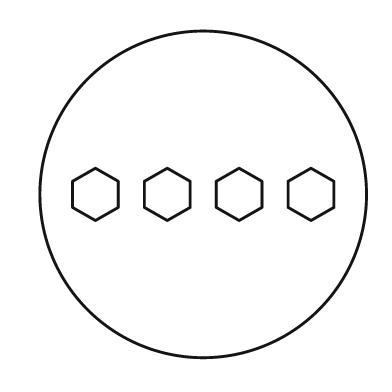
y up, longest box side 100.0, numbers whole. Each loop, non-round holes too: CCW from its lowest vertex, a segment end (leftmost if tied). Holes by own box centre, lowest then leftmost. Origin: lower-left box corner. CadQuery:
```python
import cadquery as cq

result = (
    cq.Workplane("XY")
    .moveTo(50.0, 50.0)
    .circle(50.0)
    .moveTo(17.0, 42.0)
    .lineTo(24.0, 46.0)
    .lineTo(24.0, 54.0)
    .lineTo(17.0, 58.0)
    .lineTo(10.0, 54.0)
    .lineTo(10.0, 46.0)
    .close()
    .moveTo(39.0, 42.0)
    .lineTo(46.0, 46.0)
    .lineTo(46.0, 54.0)
    .lineTo(39.0, 58.0)
    .lineTo(32.0, 54.0)
    .lineTo(32.0, 46.0)
    .close()
    .moveTo(61.0, 42.0)
    .lineTo(68.0, 46.0)
    .lineTo(68.0, 54.0)
    .lineTo(61.0, 58.0)
    .lineTo(54.0, 54.0)
    .lineTo(54.0, 46.0)
    .close()
    .moveTo(83.0, 42.0)
    .lineTo(90.0, 46.0)
    .lineTo(90.0, 54.0)
    .lineTo(83.0, 58.0)
    .lineTo(76.0, 54.0)
    .lineTo(76.0, 46.0)
    .close()
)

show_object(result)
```